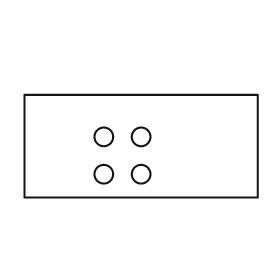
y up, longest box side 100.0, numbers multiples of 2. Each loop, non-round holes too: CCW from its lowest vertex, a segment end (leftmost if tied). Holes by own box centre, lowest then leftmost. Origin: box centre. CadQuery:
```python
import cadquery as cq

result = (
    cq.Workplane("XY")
    .moveTo(-50.0, -22.0)
    .lineTo(50.0, -22.0)
    .lineTo(50.0, 22.0)
    .lineTo(-50.0, 22.0)
    .close()
    .moveTo(-16.0, -12.0)
    .circle(4.0)
    .moveTo(0.0, -12.0)
    .circle(4.0)
    .moveTo(-16.0, 4.0)
    .circle(4.0)
    .moveTo(0.0, 4.0)
    .circle(4.0)
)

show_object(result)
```